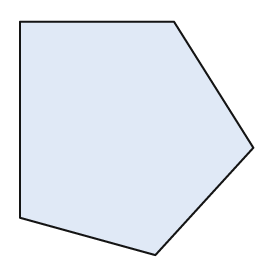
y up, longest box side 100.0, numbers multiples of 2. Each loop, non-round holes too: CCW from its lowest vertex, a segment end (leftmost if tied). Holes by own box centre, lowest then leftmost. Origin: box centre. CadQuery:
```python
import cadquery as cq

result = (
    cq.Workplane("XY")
    .moveTo(8.0, -50.0)
    .lineTo(50.0, -4.0)
    .lineTo(16.0, 50.0)
    .lineTo(-50.0, 50.0)
    .lineTo(-50.0, -34.0)
    .close()
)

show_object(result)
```